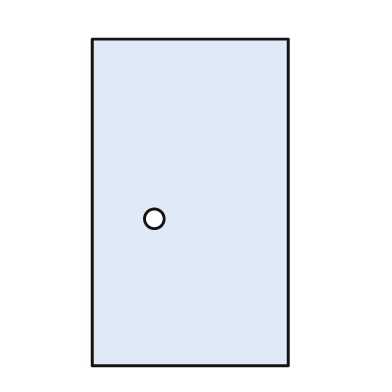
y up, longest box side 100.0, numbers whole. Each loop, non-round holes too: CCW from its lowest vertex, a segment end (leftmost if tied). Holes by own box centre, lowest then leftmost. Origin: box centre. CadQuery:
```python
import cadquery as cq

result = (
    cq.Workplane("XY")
    .moveTo(-30.0, -50.0)
    .lineTo(30.0, -50.0)
    .lineTo(30.0, 50.0)
    .lineTo(-30.0, 50.0)
    .close()
    .moveTo(-11.0, -5.0)
    .circle(3.0)
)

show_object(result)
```